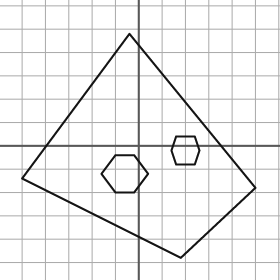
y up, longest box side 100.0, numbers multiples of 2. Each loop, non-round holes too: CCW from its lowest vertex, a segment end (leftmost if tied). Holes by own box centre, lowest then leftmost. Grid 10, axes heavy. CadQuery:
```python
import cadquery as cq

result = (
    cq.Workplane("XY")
    .moveTo(18.0, -48.0)
    .lineTo(50.0, -18.0)
    .lineTo(-4.0, 48.0)
    .lineTo(-50.0, -14.0)
    .close()
    .moveTo(-10.0, -20.0)
    .lineTo(-2.0, -20.0)
    .lineTo(4.0, -12.0)
    .lineTo(-2.0, -4.0)
    .lineTo(-10.0, -4.0)
    .lineTo(-16.0, -12.0)
    .close()
    .moveTo(16.0, -8.0)
    .lineTo(24.0, -8.0)
    .lineTo(26.0, -2.0)
    .lineTo(24.0, 4.0)
    .lineTo(16.0, 4.0)
    .lineTo(14.0, -2.0)
    .close()
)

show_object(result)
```